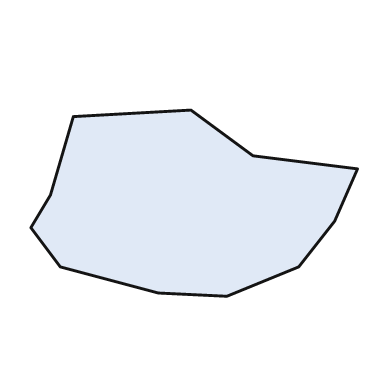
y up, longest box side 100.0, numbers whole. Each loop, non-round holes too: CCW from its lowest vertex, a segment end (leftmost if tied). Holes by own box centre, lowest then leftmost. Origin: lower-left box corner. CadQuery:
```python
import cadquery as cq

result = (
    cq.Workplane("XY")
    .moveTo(60.0, 0.0)
    .lineTo(82.0, 9.0)
    .lineTo(93.0, 23.0)
    .lineTo(100.0, 39.0)
    .lineTo(68.0, 43.0)
    .lineTo(49.0, 57.0)
    .lineTo(13.0, 55.0)
    .lineTo(6.0, 31.0)
    .lineTo(0.0, 21.0)
    .lineTo(9.0, 9.0)
    .lineTo(39.0, 1.0)
    .close()
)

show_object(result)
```